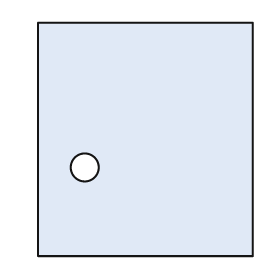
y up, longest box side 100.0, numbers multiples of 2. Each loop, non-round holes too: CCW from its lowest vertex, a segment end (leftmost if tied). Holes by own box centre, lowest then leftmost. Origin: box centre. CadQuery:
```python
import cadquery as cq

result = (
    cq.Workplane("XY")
    .moveTo(-46.0, -50.0)
    .lineTo(46.0, -50.0)
    .lineTo(46.0, 50.0)
    .lineTo(-46.0, 50.0)
    .close()
    .moveTo(-26.0, -12.0)
    .circle(6.0)
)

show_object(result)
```